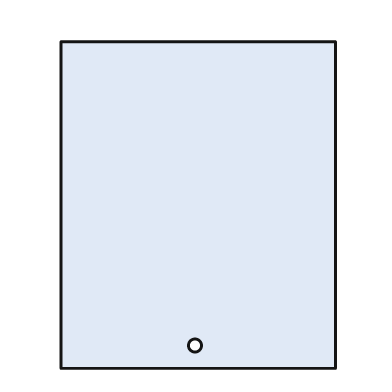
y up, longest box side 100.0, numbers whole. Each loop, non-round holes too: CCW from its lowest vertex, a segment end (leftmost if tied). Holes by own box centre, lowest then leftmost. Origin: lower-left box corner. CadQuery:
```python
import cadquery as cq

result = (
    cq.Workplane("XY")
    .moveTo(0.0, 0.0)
    .lineTo(84.0, 0.0)
    .lineTo(84.0, 100.0)
    .lineTo(0.0, 100.0)
    .close()
    .moveTo(41.0, 7.0)
    .circle(2.0)
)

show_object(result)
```